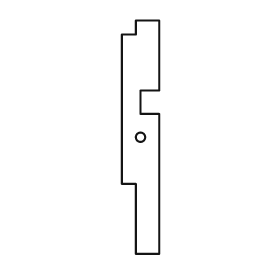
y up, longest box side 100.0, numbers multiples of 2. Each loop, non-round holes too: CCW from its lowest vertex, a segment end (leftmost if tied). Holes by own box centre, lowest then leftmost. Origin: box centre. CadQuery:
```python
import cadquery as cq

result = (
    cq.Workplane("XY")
    .moveTo(-2.0, -50.0)
    .lineTo(8.0, -50.0)
    .lineTo(8.0, 10.0)
    .lineTo(0.0, 10.0)
    .lineTo(0.0, 20.0)
    .lineTo(8.0, 20.0)
    .lineTo(8.0, 50.0)
    .lineTo(-2.0, 50.0)
    .lineTo(-2.0, 44.0)
    .lineTo(-8.0, 44.0)
    .lineTo(-8.0, -20.0)
    .lineTo(-2.0, -20.0)
    .close()
    .moveTo(0.0, 0.0)
    .circle(2.0)
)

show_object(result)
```